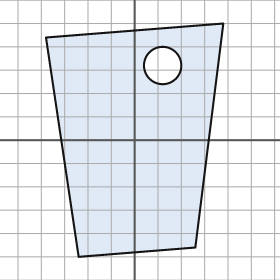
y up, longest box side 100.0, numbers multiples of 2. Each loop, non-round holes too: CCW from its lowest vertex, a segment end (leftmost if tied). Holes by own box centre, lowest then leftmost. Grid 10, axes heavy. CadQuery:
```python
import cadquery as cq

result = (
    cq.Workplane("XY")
    .moveTo(-24.0, -50.0)
    .lineTo(26.0, -46.0)
    .lineTo(38.0, 50.0)
    .lineTo(-38.0, 44.0)
    .close()
    .moveTo(12.0, 32.0)
    .circle(8.0)
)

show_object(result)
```